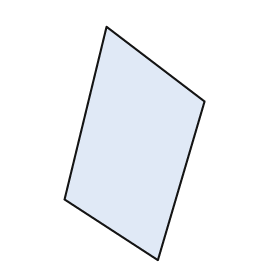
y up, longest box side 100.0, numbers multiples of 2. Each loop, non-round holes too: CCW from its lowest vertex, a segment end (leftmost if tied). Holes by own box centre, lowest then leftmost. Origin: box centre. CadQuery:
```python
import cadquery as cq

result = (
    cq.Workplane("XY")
    .moveTo(10.0, -50.0)
    .lineTo(30.0, 18.0)
    .lineTo(-12.0, 50.0)
    .lineTo(-30.0, -24.0)
    .close()
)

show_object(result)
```